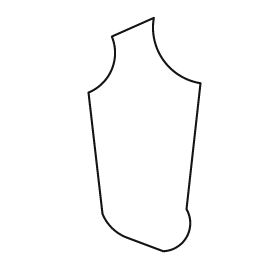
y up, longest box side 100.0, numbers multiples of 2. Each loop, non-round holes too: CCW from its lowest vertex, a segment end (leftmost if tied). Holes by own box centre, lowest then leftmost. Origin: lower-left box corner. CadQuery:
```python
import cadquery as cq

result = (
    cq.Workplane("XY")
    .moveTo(32.0, 0.0)
    .threePointArc((42.0, 6.0), (42.0, 18.0))
    .lineTo(48.0, 72.0)
    .threePointArc((32.0, 82.0), (28.0, 100.0))
    .lineTo(10.0, 92.0)
    .threePointArc((10.0, 78.0), (0.0, 68.0))
    .lineTo(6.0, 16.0)
    .threePointArc((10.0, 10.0), (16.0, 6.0))
    .close()
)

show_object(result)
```